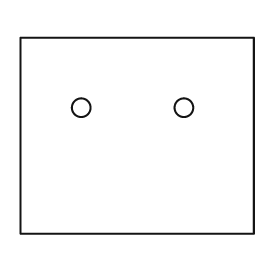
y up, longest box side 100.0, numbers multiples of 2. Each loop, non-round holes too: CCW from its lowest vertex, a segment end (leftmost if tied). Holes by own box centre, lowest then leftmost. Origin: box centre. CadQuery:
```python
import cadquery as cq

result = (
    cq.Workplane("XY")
    .moveTo(-50.0, -42.0)
    .lineTo(50.0, -42.0)
    .lineTo(50.0, 42.0)
    .lineTo(-50.0, 42.0)
    .close()
    .moveTo(-24.0, 12.0)
    .circle(4.0)
    .moveTo(20.0, 12.0)
    .circle(4.0)
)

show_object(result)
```